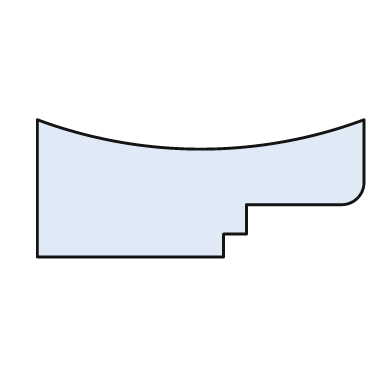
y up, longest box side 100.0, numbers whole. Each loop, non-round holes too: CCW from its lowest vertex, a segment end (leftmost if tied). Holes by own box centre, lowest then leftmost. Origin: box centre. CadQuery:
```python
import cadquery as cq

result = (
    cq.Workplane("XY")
    .moveTo(-50.0, -21.0)
    .lineTo(7.0, -21.0)
    .lineTo(7.0, -14.0)
    .lineTo(14.0, -14.0)
    .lineTo(14.0, -5.0)
    .lineTo(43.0, -5.0)
    .threePointArc((48.0, -3.0), (50.0, 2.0))
    .lineTo(50.0, 21.0)
    .threePointArc((0.0, 12.0), (-50.0, 21.0))
    .close()
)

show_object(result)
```